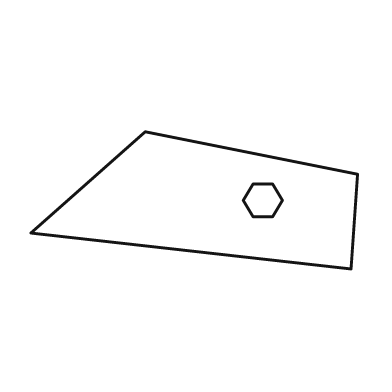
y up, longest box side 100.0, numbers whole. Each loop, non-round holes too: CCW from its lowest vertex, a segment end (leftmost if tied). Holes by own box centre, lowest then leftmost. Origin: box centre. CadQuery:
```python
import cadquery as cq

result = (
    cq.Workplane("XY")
    .moveTo(48.0, -21.0)
    .lineTo(50.0, 8.0)
    .lineTo(-15.0, 21.0)
    .lineTo(-50.0, -10.0)
    .close()
    .moveTo(18.0, -5.0)
    .lineTo(24.0, -5.0)
    .lineTo(27.0, 0.0)
    .lineTo(24.0, 5.0)
    .lineTo(18.0, 5.0)
    .lineTo(15.0, 0.0)
    .close()
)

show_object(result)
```